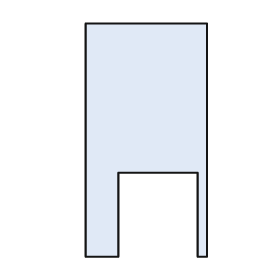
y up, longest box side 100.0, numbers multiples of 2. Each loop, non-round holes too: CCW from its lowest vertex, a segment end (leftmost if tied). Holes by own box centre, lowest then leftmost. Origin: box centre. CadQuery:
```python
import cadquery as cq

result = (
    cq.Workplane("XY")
    .moveTo(-26.0, -50.0)
    .lineTo(-12.0, -50.0)
    .lineTo(-12.0, -14.0)
    .lineTo(22.0, -14.0)
    .lineTo(22.0, -50.0)
    .lineTo(26.0, -50.0)
    .lineTo(26.0, 50.0)
    .lineTo(-26.0, 50.0)
    .close()
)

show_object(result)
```